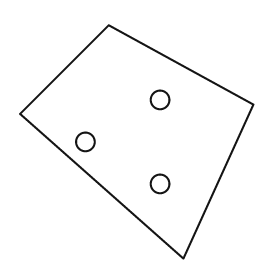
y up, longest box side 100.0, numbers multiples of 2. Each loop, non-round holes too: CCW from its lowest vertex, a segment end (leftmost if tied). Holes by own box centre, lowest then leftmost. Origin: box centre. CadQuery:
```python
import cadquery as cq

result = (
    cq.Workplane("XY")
    .moveTo(20.0, -50.0)
    .lineTo(50.0, 16.0)
    .lineTo(-12.0, 50.0)
    .lineTo(-50.0, 12.0)
    .close()
    .moveTo(10.0, -18.0)
    .circle(4.0)
    .moveTo(-22.0, 0.0)
    .circle(4.0)
    .moveTo(10.0, 18.0)
    .circle(4.0)
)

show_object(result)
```